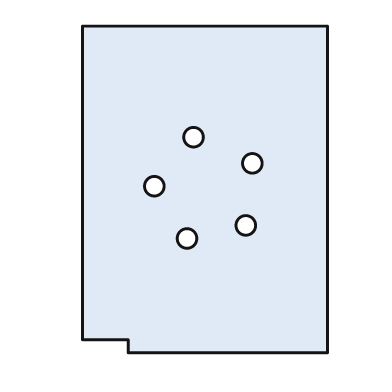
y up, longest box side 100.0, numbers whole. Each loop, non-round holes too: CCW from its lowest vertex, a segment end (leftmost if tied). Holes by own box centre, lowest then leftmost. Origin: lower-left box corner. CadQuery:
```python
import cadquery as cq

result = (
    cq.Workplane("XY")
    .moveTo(14.0, 0.0)
    .lineTo(75.0, 0.0)
    .lineTo(75.0, 100.0)
    .lineTo(0.0, 100.0)
    .lineTo(0.0, 4.0)
    .lineTo(14.0, 4.0)
    .close()
    .moveTo(32.0, 35.0)
    .circle(3.0)
    .moveTo(50.0, 39.0)
    .circle(3.0)
    .moveTo(22.0, 51.0)
    .circle(3.0)
    .moveTo(52.0, 58.0)
    .circle(3.0)
    .moveTo(34.0, 66.0)
    .circle(3.0)
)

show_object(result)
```